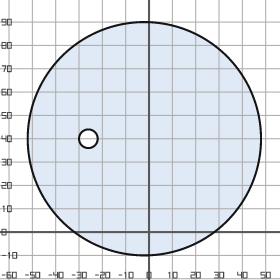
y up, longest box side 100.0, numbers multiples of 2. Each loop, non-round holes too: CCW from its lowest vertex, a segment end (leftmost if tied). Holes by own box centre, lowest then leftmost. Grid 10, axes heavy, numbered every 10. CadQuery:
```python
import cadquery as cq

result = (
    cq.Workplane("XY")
    .moveTo(-2.0, 40.0)
    .circle(50.0)
    .moveTo(-26.0, 40.0)
    .circle(4.0)
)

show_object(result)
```